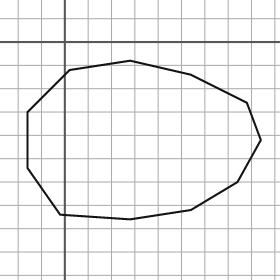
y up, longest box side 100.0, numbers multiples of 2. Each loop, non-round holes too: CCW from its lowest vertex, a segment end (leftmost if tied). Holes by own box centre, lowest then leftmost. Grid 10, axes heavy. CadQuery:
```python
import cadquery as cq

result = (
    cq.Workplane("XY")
    .moveTo(28.0, -76.0)
    .lineTo(54.0, -72.0)
    .lineTo(74.0, -60.0)
    .lineTo(84.0, -42.0)
    .lineTo(78.0, -26.0)
    .lineTo(54.0, -14.0)
    .lineTo(28.0, -8.0)
    .lineTo(2.0, -12.0)
    .lineTo(-16.0, -30.0)
    .lineTo(-16.0, -54.0)
    .lineTo(-2.0, -74.0)
    .close()
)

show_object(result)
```